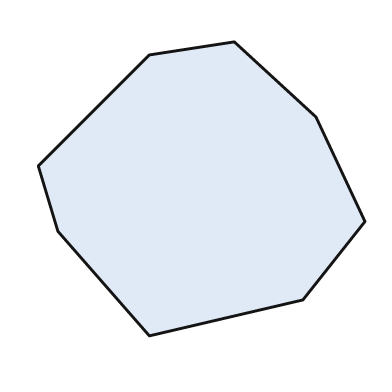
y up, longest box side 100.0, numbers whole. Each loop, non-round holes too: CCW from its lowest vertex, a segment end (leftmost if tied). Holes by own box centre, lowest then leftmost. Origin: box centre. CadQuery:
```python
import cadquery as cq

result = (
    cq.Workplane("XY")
    .moveTo(-16.0, -45.0)
    .lineTo(31.0, -34.0)
    .lineTo(50.0, -10.0)
    .lineTo(35.0, 22.0)
    .lineTo(10.0, 45.0)
    .lineTo(-16.0, 41.0)
    .lineTo(-50.0, 7.0)
    .lineTo(-44.0, -13.0)
    .close()
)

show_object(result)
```